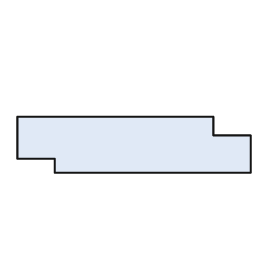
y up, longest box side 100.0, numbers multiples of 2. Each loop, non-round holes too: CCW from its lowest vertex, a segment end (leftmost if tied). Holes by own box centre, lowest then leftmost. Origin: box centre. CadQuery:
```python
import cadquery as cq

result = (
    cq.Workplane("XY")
    .moveTo(-34.0, -12.0)
    .lineTo(50.0, -12.0)
    .lineTo(50.0, 4.0)
    .lineTo(34.0, 4.0)
    .lineTo(34.0, 12.0)
    .lineTo(-50.0, 12.0)
    .lineTo(-50.0, -6.0)
    .lineTo(-34.0, -6.0)
    .close()
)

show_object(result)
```